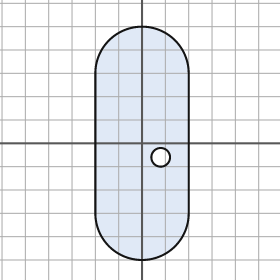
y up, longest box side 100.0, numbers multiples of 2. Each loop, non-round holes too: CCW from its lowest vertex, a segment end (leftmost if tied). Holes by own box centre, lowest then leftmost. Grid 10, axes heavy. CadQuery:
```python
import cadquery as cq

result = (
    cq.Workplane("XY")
    .moveTo(-20.0, -30.0)
    .threePointArc((0.0, -50.0), (20.0, -30.0))
    .lineTo(20.0, 30.0)
    .threePointArc((0.0, 50.0), (-20.0, 30.0))
    .close()
    .moveTo(8.0, -6.0)
    .circle(4.0)
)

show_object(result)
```